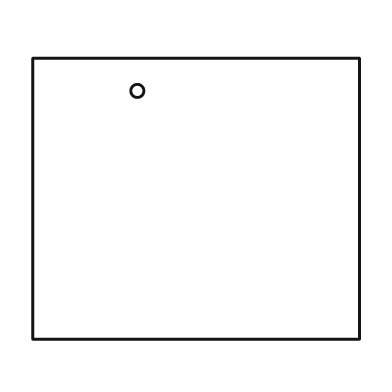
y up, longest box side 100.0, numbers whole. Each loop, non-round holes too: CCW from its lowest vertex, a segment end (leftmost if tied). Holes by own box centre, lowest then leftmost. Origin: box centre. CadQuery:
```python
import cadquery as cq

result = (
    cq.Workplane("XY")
    .moveTo(-50.0, -43.0)
    .lineTo(50.0, -43.0)
    .lineTo(50.0, 43.0)
    .lineTo(-50.0, 43.0)
    .close()
    .moveTo(-18.0, 33.0)
    .circle(2.0)
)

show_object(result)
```